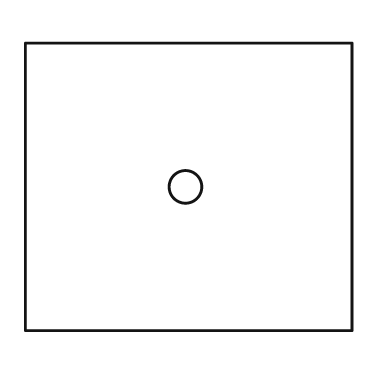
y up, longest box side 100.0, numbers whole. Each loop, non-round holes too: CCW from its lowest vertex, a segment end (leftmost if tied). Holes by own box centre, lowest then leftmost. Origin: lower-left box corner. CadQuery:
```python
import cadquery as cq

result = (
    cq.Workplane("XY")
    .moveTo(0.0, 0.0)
    .lineTo(100.0, 0.0)
    .lineTo(100.0, 88.0)
    .lineTo(0.0, 88.0)
    .close()
    .moveTo(49.0, 44.0)
    .circle(5.0)
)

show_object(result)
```